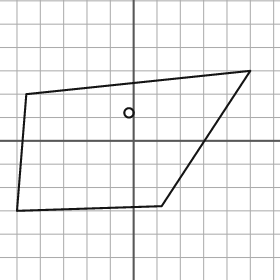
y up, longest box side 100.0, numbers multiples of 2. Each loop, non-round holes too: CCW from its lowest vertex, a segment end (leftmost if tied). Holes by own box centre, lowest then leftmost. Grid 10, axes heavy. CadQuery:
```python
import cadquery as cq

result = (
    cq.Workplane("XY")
    .moveTo(-50.0, -30.0)
    .lineTo(12.0, -28.0)
    .lineTo(50.0, 30.0)
    .lineTo(-46.0, 20.0)
    .close()
    .moveTo(-2.0, 12.0)
    .circle(2.0)
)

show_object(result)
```